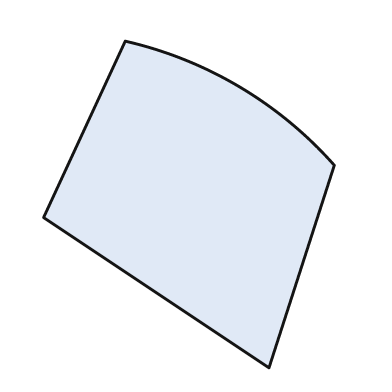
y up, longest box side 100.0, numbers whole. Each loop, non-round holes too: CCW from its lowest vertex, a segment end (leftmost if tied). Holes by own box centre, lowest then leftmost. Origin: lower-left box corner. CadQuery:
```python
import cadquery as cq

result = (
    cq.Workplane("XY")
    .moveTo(69.0, 0.0)
    .lineTo(89.0, 62.0)
    .threePointArc((60.0, 86.0), (25.0, 100.0))
    .lineTo(0.0, 46.0)
    .close()
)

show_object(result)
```